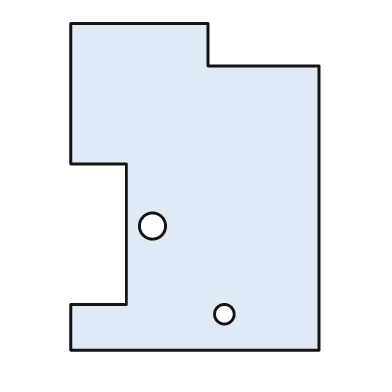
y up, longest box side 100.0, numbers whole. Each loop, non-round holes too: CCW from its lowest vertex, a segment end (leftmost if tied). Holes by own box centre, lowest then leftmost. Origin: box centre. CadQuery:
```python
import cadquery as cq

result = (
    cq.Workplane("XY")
    .moveTo(-38.0, -50.0)
    .lineTo(38.0, -50.0)
    .lineTo(38.0, 37.0)
    .lineTo(4.0, 37.0)
    .lineTo(4.0, 50.0)
    .lineTo(-38.0, 50.0)
    .lineTo(-38.0, 7.0)
    .lineTo(-21.0, 7.0)
    .lineTo(-21.0, -36.0)
    .lineTo(-38.0, -36.0)
    .close()
    .moveTo(9.0, -39.0)
    .circle(3.0)
    .moveTo(-13.0, -12.0)
    .circle(4.0)
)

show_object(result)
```